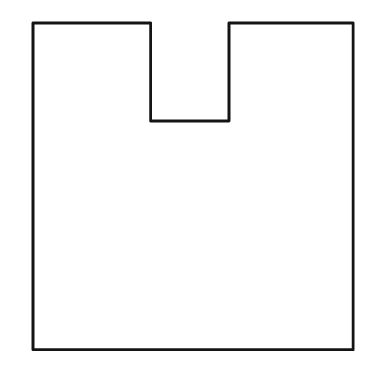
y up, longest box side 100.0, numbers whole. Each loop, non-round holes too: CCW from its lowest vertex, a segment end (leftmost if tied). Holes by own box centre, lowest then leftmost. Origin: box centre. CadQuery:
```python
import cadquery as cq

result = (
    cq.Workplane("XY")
    .moveTo(-49.0, -50.0)
    .lineTo(49.0, -50.0)
    .lineTo(49.0, 50.0)
    .lineTo(11.0, 50.0)
    .lineTo(11.0, 20.0)
    .lineTo(-13.0, 20.0)
    .lineTo(-13.0, 50.0)
    .lineTo(-49.0, 50.0)
    .close()
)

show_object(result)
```